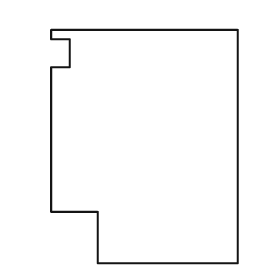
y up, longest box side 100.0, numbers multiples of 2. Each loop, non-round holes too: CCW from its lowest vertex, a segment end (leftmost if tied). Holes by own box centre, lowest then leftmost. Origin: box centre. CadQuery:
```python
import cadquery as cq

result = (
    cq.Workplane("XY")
    .moveTo(-20.0, -50.0)
    .lineTo(40.0, -50.0)
    .lineTo(40.0, 50.0)
    .lineTo(-40.0, 50.0)
    .lineTo(-40.0, 46.0)
    .lineTo(-32.0, 46.0)
    .lineTo(-32.0, 34.0)
    .lineTo(-40.0, 34.0)
    .lineTo(-40.0, -28.0)
    .lineTo(-20.0, -28.0)
    .close()
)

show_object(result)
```